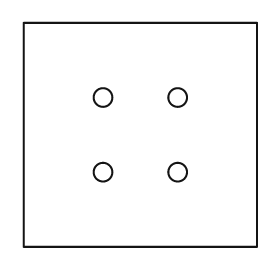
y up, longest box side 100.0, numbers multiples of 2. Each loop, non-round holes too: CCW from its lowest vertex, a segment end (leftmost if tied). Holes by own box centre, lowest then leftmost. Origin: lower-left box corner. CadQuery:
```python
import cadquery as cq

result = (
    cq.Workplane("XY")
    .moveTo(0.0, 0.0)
    .lineTo(100.0, 0.0)
    .lineTo(100.0, 96.0)
    .lineTo(0.0, 96.0)
    .close()
    .moveTo(34.0, 32.0)
    .circle(4.0)
    .moveTo(66.0, 32.0)
    .circle(4.0)
    .moveTo(34.0, 64.0)
    .circle(4.0)
    .moveTo(66.0, 64.0)
    .circle(4.0)
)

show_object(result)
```